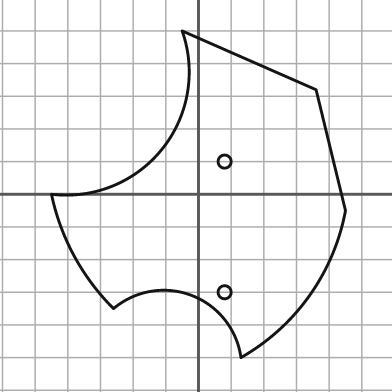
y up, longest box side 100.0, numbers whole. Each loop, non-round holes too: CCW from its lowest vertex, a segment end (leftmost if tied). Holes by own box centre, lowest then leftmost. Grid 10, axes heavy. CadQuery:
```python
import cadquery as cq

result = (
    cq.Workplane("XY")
    .moveTo(13.0, -50.0)
    .threePointArc((34.0, -31.0), (45.0, -5.0))
    .lineTo(36.0, 32.0)
    .lineTo(-5.0, 50.0)
    .threePointArc((-11.0, 14.0), (-45.0, 0.0))
    .threePointArc((-38.0, -19.0), (-26.0, -35.0))
    .threePointArc((-2.0, -31.0), (13.0, -50.0))
    .close()
    .moveTo(8.0, -30.0)
    .circle(2.0)
    .moveTo(8.0, 10.0)
    .circle(2.0)
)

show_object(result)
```